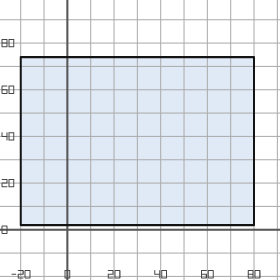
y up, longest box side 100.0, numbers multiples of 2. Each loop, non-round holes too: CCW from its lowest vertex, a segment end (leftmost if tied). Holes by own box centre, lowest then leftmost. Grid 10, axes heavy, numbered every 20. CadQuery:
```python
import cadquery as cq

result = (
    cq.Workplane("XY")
    .moveTo(-20.0, 2.0)
    .lineTo(80.0, 2.0)
    .lineTo(80.0, 74.0)
    .lineTo(-20.0, 74.0)
    .close()
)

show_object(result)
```